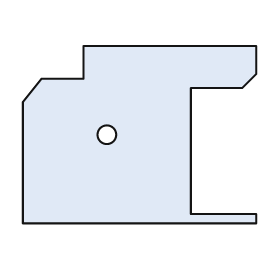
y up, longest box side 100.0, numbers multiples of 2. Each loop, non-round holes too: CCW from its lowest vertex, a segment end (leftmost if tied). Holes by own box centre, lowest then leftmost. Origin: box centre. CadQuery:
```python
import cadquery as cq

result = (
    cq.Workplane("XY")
    .moveTo(-50.0, -38.0)
    .lineTo(50.0, -38.0)
    .lineTo(50.0, -34.0)
    .lineTo(22.0, -34.0)
    .lineTo(22.0, 20.0)
    .lineTo(44.0, 20.0)
    .lineTo(50.0, 26.0)
    .lineTo(50.0, 38.0)
    .lineTo(-24.0, 38.0)
    .lineTo(-24.0, 24.0)
    .lineTo(-42.0, 24.0)
    .lineTo(-50.0, 14.0)
    .close()
    .moveTo(-14.0, 0.0)
    .circle(4.0)
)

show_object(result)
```